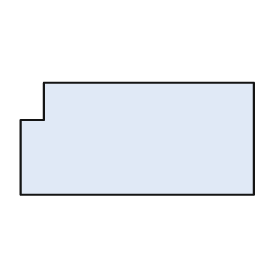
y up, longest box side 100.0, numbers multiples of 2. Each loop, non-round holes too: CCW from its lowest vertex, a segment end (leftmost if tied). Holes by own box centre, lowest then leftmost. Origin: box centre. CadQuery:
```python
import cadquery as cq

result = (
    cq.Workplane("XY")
    .moveTo(-50.0, -24.0)
    .lineTo(50.0, -24.0)
    .lineTo(50.0, 24.0)
    .lineTo(-40.0, 24.0)
    .lineTo(-40.0, 8.0)
    .lineTo(-50.0, 8.0)
    .close()
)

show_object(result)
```